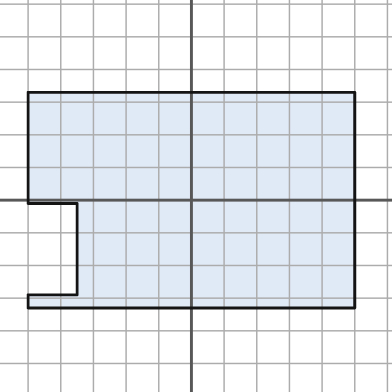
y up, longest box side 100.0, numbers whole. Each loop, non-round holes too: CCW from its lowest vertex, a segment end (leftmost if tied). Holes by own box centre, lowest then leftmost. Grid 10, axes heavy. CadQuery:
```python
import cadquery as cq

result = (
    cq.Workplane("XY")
    .moveTo(-50.0, -33.0)
    .lineTo(50.0, -33.0)
    .lineTo(50.0, 33.0)
    .lineTo(-50.0, 33.0)
    .lineTo(-50.0, -1.0)
    .lineTo(-35.0, -1.0)
    .lineTo(-35.0, -29.0)
    .lineTo(-50.0, -29.0)
    .close()
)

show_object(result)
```